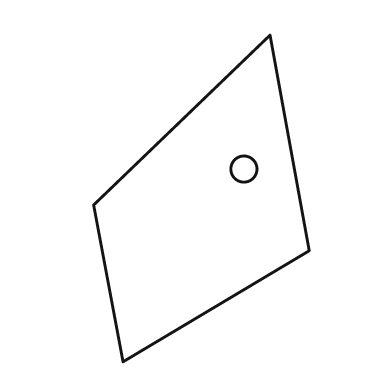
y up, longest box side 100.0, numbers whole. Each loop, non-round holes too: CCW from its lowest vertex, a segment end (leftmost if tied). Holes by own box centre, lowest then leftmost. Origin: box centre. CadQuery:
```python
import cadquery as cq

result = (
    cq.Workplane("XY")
    .moveTo(-24.0, -50.0)
    .lineTo(33.0, -16.0)
    .lineTo(21.0, 50.0)
    .lineTo(-33.0, -2.0)
    .close()
    .moveTo(13.0, 9.0)
    .circle(4.0)
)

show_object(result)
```